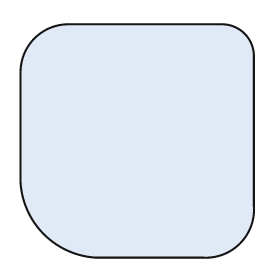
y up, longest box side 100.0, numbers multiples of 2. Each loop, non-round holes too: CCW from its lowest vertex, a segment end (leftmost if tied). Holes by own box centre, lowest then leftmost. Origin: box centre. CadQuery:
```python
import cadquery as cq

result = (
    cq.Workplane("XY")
    .moveTo(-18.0, -50.0)
    .lineTo(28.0, -50.0)
    .threePointArc((44.0, -44.0), (50.0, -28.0))
    .lineTo(50.0, 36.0)
    .threePointArc((46.0, 46.0), (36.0, 50.0))
    .lineTo(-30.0, 50.0)
    .threePointArc((-44.0, 44.0), (-50.0, 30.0))
    .lineTo(-50.0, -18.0)
    .threePointArc((-40.0, -40.0), (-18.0, -50.0))
    .close()
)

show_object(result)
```